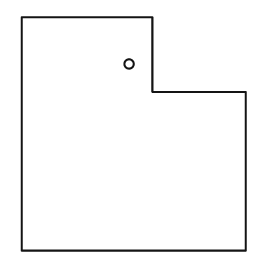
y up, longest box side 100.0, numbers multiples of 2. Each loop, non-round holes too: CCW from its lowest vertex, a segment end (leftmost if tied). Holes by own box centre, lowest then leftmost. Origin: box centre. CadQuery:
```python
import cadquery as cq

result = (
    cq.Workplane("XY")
    .moveTo(-48.0, -50.0)
    .lineTo(48.0, -50.0)
    .lineTo(48.0, 18.0)
    .lineTo(8.0, 18.0)
    .lineTo(8.0, 50.0)
    .lineTo(-48.0, 50.0)
    .close()
    .moveTo(-2.0, 30.0)
    .circle(2.0)
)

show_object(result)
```